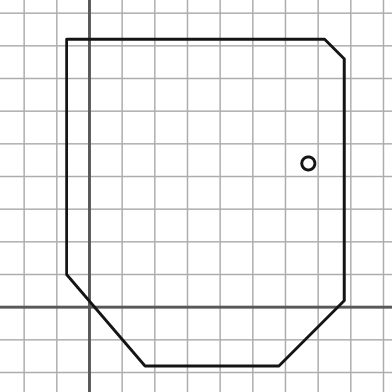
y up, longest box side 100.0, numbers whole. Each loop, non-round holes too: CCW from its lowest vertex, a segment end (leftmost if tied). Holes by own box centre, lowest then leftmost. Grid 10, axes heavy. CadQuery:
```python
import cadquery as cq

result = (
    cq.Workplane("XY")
    .moveTo(17.0, -18.0)
    .lineTo(58.0, -18.0)
    .lineTo(78.0, 2.0)
    .lineTo(78.0, 76.0)
    .lineTo(72.0, 82.0)
    .lineTo(-7.0, 82.0)
    .lineTo(-7.0, 10.0)
    .close()
    .moveTo(67.0, 44.0)
    .circle(2.0)
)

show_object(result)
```